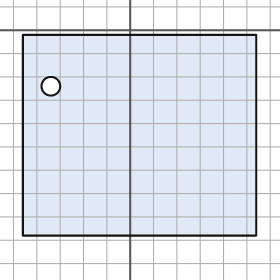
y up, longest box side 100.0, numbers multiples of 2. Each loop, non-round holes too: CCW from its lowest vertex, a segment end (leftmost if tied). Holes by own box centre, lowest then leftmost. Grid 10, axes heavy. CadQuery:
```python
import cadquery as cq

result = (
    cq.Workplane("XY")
    .moveTo(-46.0, -88.0)
    .lineTo(54.0, -88.0)
    .lineTo(54.0, -2.0)
    .lineTo(-46.0, -2.0)
    .close()
    .moveTo(-34.0, -24.0)
    .circle(4.0)
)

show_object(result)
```